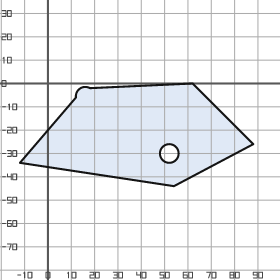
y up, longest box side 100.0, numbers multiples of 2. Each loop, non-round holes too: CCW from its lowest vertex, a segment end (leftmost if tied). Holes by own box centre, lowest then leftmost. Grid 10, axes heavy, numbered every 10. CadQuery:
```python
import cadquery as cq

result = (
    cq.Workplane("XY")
    .moveTo(54.0, -44.0)
    .lineTo(88.0, -26.0)
    .lineTo(62.0, 0.0)
    .lineTo(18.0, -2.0)
    .threePointArc((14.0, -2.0), (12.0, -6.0))
    .lineTo(-12.0, -34.0)
    .close()
    .moveTo(52.0, -30.0)
    .circle(4.0)
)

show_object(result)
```